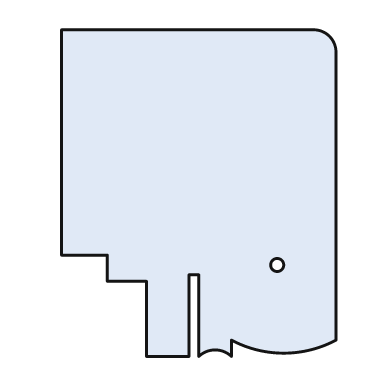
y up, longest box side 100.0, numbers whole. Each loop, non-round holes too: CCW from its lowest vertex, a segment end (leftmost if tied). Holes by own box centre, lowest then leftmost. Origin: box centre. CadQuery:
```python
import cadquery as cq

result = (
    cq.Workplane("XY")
    .moveTo(-16.0, -50.0)
    .lineTo(-3.0, -50.0)
    .lineTo(-3.0, -25.0)
    .lineTo(0.0, -25.0)
    .lineTo(0.0, -50.0)
    .threePointArc((5.0, -48.0), (10.0, -50.0))
    .lineTo(10.0, -45.0)
    .threePointArc((26.0, -49.0), (42.0, -45.0))
    .lineTo(42.0, 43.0)
    .threePointArc((40.0, 48.0), (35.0, 50.0))
    .lineTo(-42.0, 50.0)
    .lineTo(-42.0, -19.0)
    .lineTo(-28.0, -19.0)
    .lineTo(-28.0, -27.0)
    .lineTo(-16.0, -27.0)
    .close()
    .moveTo(24.0, -22.0)
    .circle(2.0)
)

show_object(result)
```